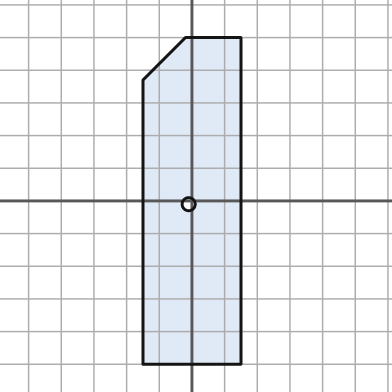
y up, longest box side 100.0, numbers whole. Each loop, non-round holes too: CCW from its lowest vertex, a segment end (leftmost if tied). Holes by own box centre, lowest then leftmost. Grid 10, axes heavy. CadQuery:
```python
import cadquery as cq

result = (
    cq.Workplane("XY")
    .moveTo(-15.0, -50.0)
    .lineTo(15.0, -50.0)
    .lineTo(15.0, 50.0)
    .lineTo(-2.0, 50.0)
    .lineTo(-15.0, 37.0)
    .close()
    .moveTo(-1.0, -1.0)
    .circle(2.0)
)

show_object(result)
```